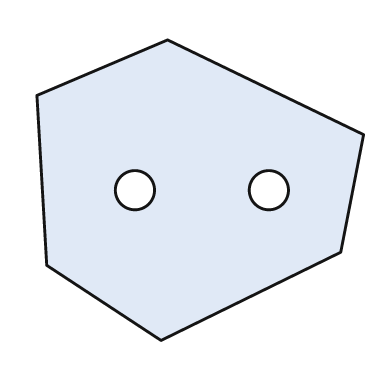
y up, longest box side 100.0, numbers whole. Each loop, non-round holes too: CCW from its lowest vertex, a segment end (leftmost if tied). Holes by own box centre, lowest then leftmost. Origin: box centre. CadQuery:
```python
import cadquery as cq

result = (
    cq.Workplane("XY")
    .moveTo(-12.0, -46.0)
    .lineTo(43.0, -19.0)
    .lineTo(50.0, 17.0)
    .lineTo(-10.0, 46.0)
    .lineTo(-50.0, 29.0)
    .lineTo(-47.0, -23.0)
    .close()
    .moveTo(-20.0, 0.0)
    .circle(6.0)
    .moveTo(21.0, 0.0)
    .circle(6.0)
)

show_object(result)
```